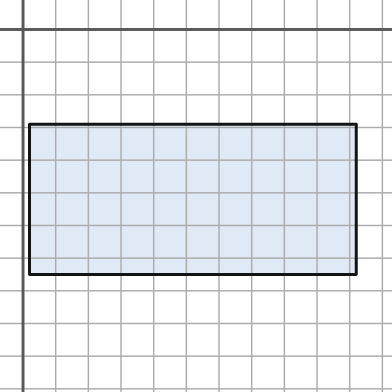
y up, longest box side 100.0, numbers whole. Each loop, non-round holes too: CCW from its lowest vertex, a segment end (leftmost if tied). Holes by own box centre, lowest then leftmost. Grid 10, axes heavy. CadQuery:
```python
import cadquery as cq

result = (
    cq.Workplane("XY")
    .moveTo(2.0, -75.0)
    .lineTo(102.0, -75.0)
    .lineTo(102.0, -29.0)
    .lineTo(2.0, -29.0)
    .close()
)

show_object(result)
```